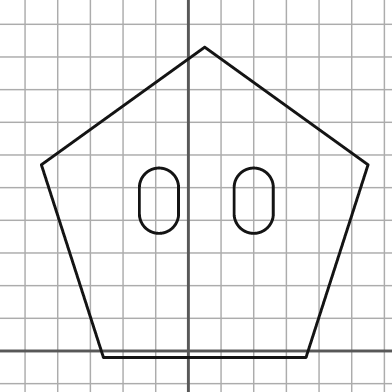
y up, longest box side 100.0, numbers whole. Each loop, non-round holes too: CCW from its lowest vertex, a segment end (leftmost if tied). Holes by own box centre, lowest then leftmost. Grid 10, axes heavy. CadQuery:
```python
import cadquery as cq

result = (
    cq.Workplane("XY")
    .moveTo(-26.0, -2.0)
    .lineTo(36.0, -2.0)
    .lineTo(55.0, 57.0)
    .lineTo(5.0, 93.0)
    .lineTo(-45.0, 57.0)
    .close()
    .moveTo(-15.0, 42.0)
    .threePointArc((-9.0, 36.0), (-3.0, 42.0))
    .lineTo(-3.0, 50.0)
    .threePointArc((-9.0, 56.0), (-15.0, 50.0))
    .close()
    .moveTo(14.0, 42.0)
    .threePointArc((20.0, 36.0), (26.0, 42.0))
    .lineTo(26.0, 50.0)
    .threePointArc((20.0, 56.0), (14.0, 50.0))
    .close()
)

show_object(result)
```